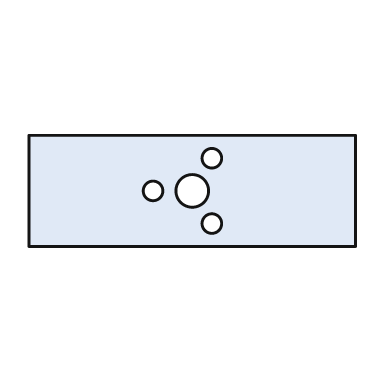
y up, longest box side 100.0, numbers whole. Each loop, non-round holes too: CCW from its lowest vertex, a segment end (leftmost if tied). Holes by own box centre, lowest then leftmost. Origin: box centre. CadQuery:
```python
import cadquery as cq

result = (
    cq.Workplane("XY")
    .moveTo(-50.0, -17.0)
    .lineTo(50.0, -17.0)
    .lineTo(50.0, 17.0)
    .lineTo(-50.0, 17.0)
    .close()
    .moveTo(6.0, -10.0)
    .circle(3.0)
    .moveTo(-12.0, 0.0)
    .circle(3.0)
    .moveTo(0.0, 0.0)
    .circle(5.0)
    .moveTo(6.0, 10.0)
    .circle(3.0)
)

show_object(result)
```